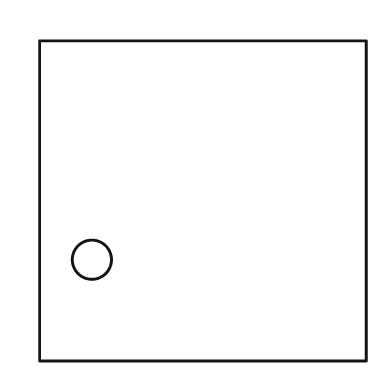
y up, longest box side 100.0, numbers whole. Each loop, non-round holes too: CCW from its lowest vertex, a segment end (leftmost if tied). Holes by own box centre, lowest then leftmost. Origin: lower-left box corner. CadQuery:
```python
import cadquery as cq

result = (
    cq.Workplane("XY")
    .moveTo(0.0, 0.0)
    .lineTo(100.0, 0.0)
    .lineTo(100.0, 98.0)
    .lineTo(0.0, 98.0)
    .close()
    .moveTo(16.0, 31.0)
    .circle(6.0)
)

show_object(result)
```